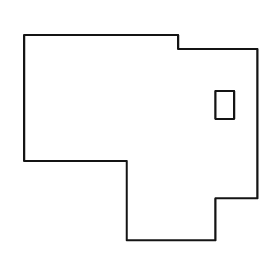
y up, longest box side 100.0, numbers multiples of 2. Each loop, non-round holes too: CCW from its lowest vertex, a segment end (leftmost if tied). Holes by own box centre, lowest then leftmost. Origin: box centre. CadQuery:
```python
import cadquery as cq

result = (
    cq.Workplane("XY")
    .moveTo(-6.0, -44.0)
    .lineTo(32.0, -44.0)
    .lineTo(32.0, -26.0)
    .lineTo(50.0, -26.0)
    .lineTo(50.0, 38.0)
    .lineTo(16.0, 38.0)
    .lineTo(16.0, 44.0)
    .lineTo(-50.0, 44.0)
    .lineTo(-50.0, -10.0)
    .lineTo(-6.0, -10.0)
    .close()
    .moveTo(32.0, 8.0)
    .lineTo(40.0, 8.0)
    .lineTo(40.0, 20.0)
    .lineTo(32.0, 20.0)
    .close()
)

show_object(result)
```